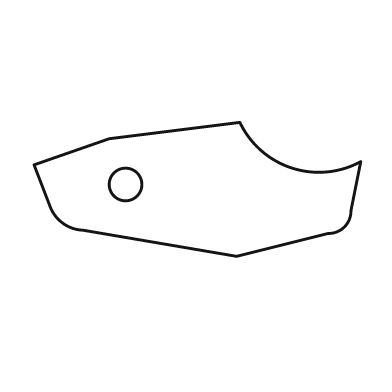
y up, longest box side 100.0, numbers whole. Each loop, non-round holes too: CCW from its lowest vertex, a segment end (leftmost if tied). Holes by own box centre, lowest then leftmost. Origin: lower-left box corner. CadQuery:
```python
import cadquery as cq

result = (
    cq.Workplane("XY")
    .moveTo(62.0, 0.0)
    .lineTo(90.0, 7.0)
    .threePointArc((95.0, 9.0), (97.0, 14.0))
    .lineTo(100.0, 29.0)
    .threePointArc((79.0, 27.0), (63.0, 41.0))
    .lineTo(23.0, 36.0)
    .lineTo(0.0, 28.0)
    .lineTo(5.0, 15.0)
    .threePointArc((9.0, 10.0), (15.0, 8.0))
    .close()
    .moveTo(28.0, 22.0)
    .circle(5.0)
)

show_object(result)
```